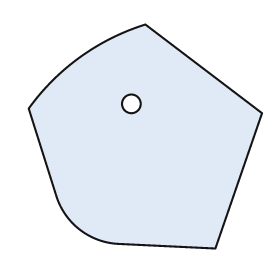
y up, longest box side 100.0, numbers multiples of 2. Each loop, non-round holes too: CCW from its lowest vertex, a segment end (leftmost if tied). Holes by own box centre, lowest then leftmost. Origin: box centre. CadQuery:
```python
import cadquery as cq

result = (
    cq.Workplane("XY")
    .moveTo(30.0, -48.0)
    .lineTo(50.0, 10.0)
    .lineTo(0.0, 48.0)
    .threePointArc((-28.0, 34.0), (-50.0, 12.0))
    .lineTo(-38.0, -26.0)
    .threePointArc((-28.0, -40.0), (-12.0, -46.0))
    .close()
    .moveTo(-6.0, 14.0)
    .circle(4.0)
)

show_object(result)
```